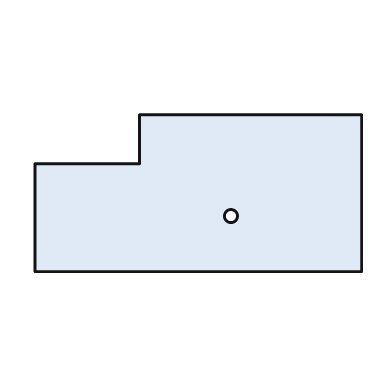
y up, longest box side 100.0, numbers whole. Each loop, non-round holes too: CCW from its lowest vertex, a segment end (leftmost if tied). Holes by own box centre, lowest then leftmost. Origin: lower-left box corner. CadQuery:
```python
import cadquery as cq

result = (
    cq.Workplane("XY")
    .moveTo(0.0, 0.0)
    .lineTo(100.0, 0.0)
    .lineTo(100.0, 48.0)
    .lineTo(32.0, 48.0)
    .lineTo(32.0, 33.0)
    .lineTo(0.0, 33.0)
    .close()
    .moveTo(60.0, 17.0)
    .circle(2.0)
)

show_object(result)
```